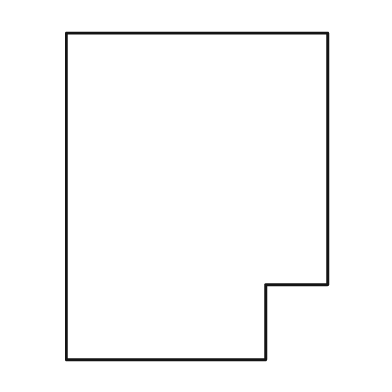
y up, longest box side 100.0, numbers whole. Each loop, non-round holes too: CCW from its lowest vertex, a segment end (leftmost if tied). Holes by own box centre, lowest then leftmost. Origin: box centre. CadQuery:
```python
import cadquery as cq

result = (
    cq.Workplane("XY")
    .moveTo(-40.0, -50.0)
    .lineTo(21.0, -50.0)
    .lineTo(21.0, -27.0)
    .lineTo(40.0, -27.0)
    .lineTo(40.0, 50.0)
    .lineTo(-40.0, 50.0)
    .close()
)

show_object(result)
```